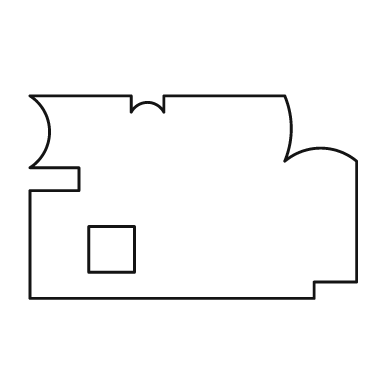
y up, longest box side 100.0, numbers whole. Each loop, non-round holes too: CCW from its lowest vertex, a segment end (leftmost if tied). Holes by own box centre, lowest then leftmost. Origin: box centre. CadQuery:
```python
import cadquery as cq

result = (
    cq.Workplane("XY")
    .moveTo(-50.0, -31.0)
    .lineTo(37.0, -31.0)
    .lineTo(37.0, -26.0)
    .lineTo(50.0, -26.0)
    .lineTo(50.0, 11.0)
    .threePointArc((39.0, 15.0), (28.0, 11.0))
    .threePointArc((30.0, 21.0), (28.0, 31.0))
    .lineTo(-9.0, 31.0)
    .lineTo(-9.0, 26.0)
    .threePointArc((-14.0, 29.0), (-19.0, 26.0))
    .lineTo(-19.0, 31.0)
    .lineTo(-50.0, 31.0)
    .threePointArc((-44.0, 20.0), (-50.0, 9.0))
    .lineTo(-35.0, 9.0)
    .lineTo(-35.0, 2.0)
    .lineTo(-50.0, 2.0)
    .close()
    .moveTo(-32.0, -23.0)
    .lineTo(-18.0, -23.0)
    .lineTo(-18.0, -9.0)
    .lineTo(-32.0, -9.0)
    .close()
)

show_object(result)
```